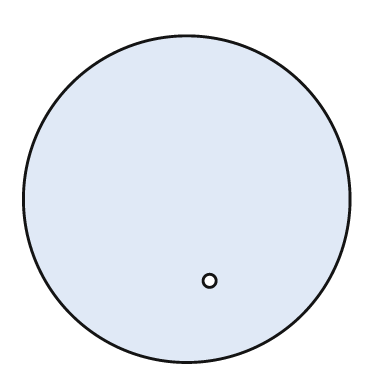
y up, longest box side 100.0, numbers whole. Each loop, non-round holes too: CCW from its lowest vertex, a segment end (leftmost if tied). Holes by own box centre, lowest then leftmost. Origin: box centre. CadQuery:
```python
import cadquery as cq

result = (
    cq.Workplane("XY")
    .moveTo(0.0, 0.0)
    .circle(50.0)
    .moveTo(7.0, -25.0)
    .circle(2.0)
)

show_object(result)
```